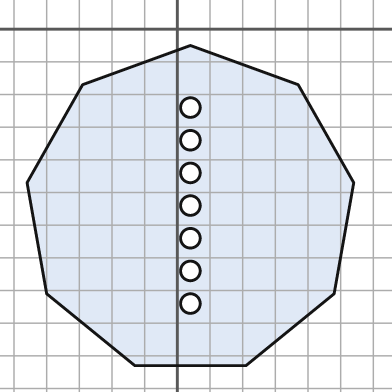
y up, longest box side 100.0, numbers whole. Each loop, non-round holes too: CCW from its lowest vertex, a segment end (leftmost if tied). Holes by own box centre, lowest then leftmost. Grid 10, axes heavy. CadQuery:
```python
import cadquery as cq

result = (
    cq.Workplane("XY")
    .moveTo(-13.0, -103.0)
    .lineTo(21.0, -103.0)
    .lineTo(48.0, -81.0)
    .lineTo(54.0, -47.0)
    .lineTo(37.0, -17.0)
    .lineTo(4.0, -5.0)
    .lineTo(-29.0, -17.0)
    .lineTo(-46.0, -47.0)
    .lineTo(-40.0, -81.0)
    .close()
    .moveTo(4.0, -84.0)
    .circle(3.0)
    .moveTo(4.0, -74.0)
    .circle(3.0)
    .moveTo(4.0, -64.0)
    .circle(3.0)
    .moveTo(4.0, -54.0)
    .circle(3.0)
    .moveTo(4.0, -44.0)
    .circle(3.0)
    .moveTo(4.0, -34.0)
    .circle(3.0)
    .moveTo(4.0, -24.0)
    .circle(3.0)
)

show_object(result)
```